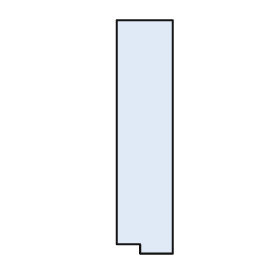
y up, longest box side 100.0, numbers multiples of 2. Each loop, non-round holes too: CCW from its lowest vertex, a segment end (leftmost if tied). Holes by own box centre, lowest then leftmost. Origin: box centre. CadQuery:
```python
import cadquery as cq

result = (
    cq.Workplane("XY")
    .moveTo(-2.0, -50.0)
    .lineTo(12.0, -50.0)
    .lineTo(12.0, 50.0)
    .lineTo(-12.0, 50.0)
    .lineTo(-12.0, -46.0)
    .lineTo(-2.0, -46.0)
    .close()
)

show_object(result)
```